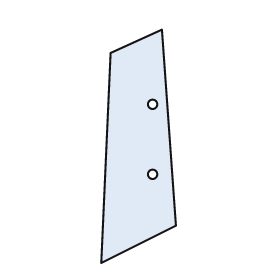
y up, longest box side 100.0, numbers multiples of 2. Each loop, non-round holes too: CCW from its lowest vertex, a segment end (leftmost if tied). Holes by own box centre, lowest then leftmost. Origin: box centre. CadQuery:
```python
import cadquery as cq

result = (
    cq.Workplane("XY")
    .moveTo(-16.0, -50.0)
    .lineTo(16.0, -34.0)
    .lineTo(10.0, 50.0)
    .lineTo(-12.0, 40.0)
    .close()
    .moveTo(6.0, -12.0)
    .circle(2.0)
    .moveTo(6.0, 18.0)
    .circle(2.0)
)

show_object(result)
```